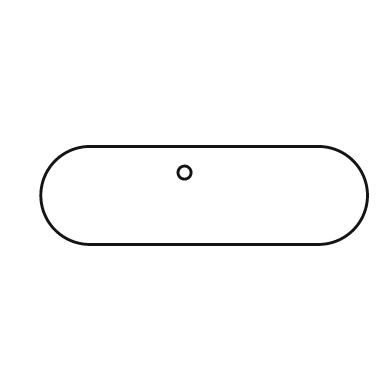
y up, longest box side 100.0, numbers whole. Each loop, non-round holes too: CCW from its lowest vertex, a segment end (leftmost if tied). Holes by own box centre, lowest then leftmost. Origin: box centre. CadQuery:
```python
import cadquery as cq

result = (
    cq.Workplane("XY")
    .moveTo(-35.0, -15.0)
    .lineTo(35.0, -15.0)
    .threePointArc((50.0, 0.0), (35.0, 15.0))
    .lineTo(-35.0, 15.0)
    .threePointArc((-50.0, 0.0), (-35.0, -15.0))
    .close()
    .moveTo(-6.0, 7.0)
    .circle(2.0)
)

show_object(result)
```